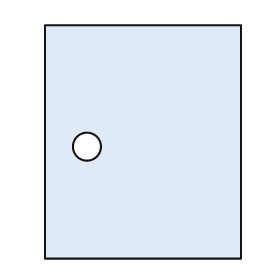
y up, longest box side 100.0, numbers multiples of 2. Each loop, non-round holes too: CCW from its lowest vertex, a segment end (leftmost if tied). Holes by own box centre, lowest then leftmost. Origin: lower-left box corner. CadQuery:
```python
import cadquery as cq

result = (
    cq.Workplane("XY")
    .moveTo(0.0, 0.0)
    .lineTo(84.0, 0.0)
    .lineTo(84.0, 100.0)
    .lineTo(0.0, 100.0)
    .close()
    .moveTo(18.0, 48.0)
    .circle(6.0)
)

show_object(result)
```